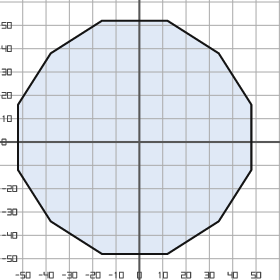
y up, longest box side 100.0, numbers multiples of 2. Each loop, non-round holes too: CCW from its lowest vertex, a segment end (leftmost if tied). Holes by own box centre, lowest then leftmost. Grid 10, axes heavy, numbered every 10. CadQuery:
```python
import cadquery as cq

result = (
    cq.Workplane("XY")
    .moveTo(-16.0, -48.0)
    .lineTo(12.0, -48.0)
    .lineTo(34.0, -34.0)
    .lineTo(48.0, -12.0)
    .lineTo(48.0, 16.0)
    .lineTo(34.0, 38.0)
    .lineTo(12.0, 52.0)
    .lineTo(-16.0, 52.0)
    .lineTo(-38.0, 38.0)
    .lineTo(-52.0, 16.0)
    .lineTo(-52.0, -12.0)
    .lineTo(-38.0, -34.0)
    .close()
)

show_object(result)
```